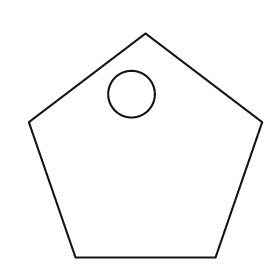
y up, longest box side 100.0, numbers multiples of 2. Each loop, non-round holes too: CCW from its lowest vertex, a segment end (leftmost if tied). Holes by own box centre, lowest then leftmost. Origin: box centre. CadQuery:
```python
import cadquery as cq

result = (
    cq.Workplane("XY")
    .moveTo(-30.0, -48.0)
    .lineTo(30.0, -48.0)
    .lineTo(50.0, 10.0)
    .lineTo(0.0, 48.0)
    .lineTo(-50.0, 10.0)
    .close()
    .moveTo(-6.0, 22.0)
    .circle(10.0)
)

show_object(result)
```